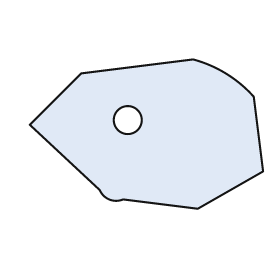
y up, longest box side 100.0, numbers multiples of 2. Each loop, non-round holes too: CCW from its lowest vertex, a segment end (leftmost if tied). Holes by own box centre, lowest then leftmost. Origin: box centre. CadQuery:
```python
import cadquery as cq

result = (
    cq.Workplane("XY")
    .moveTo(22.0, -32.0)
    .lineTo(50.0, -16.0)
    .lineTo(46.0, 16.0)
    .threePointArc((34.0, 26.0), (20.0, 32.0))
    .lineTo(-28.0, 26.0)
    .lineTo(-50.0, 4.0)
    .lineTo(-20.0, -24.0)
    .threePointArc((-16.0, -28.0), (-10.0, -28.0))
    .close()
    .moveTo(-8.0, 6.0)
    .circle(6.0)
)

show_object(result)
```